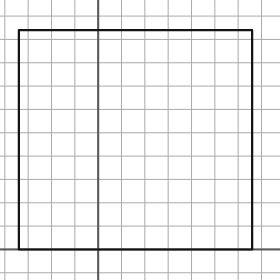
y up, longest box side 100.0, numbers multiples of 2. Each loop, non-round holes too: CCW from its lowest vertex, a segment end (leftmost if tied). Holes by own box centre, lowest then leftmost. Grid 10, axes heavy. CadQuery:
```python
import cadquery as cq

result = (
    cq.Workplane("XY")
    .moveTo(-34.0, 0.0)
    .lineTo(66.0, 0.0)
    .lineTo(66.0, 94.0)
    .lineTo(-34.0, 94.0)
    .close()
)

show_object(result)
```